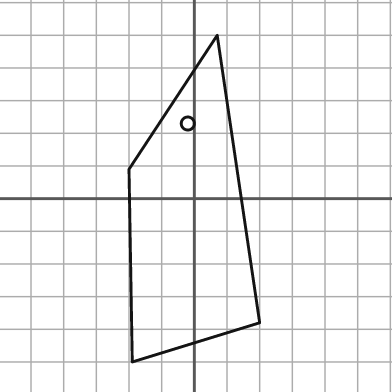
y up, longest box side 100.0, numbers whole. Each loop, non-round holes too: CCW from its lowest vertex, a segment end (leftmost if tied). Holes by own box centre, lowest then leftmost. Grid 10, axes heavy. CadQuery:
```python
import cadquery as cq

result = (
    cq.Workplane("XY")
    .moveTo(-19.0, -50.0)
    .lineTo(20.0, -38.0)
    .lineTo(7.0, 50.0)
    .lineTo(-20.0, 9.0)
    .close()
    .moveTo(-2.0, 23.0)
    .circle(2.0)
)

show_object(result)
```